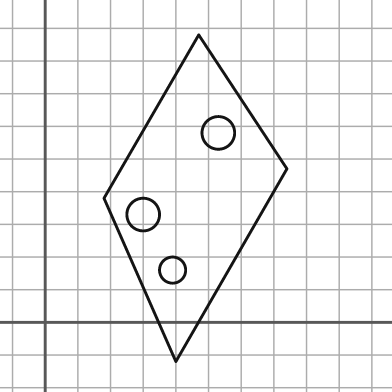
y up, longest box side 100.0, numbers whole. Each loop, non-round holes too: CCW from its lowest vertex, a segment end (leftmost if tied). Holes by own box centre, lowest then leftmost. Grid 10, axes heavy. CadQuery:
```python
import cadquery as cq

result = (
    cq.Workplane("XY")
    .moveTo(40.0, -12.0)
    .lineTo(74.0, 47.0)
    .lineTo(47.0, 88.0)
    .lineTo(18.0, 38.0)
    .close()
    .moveTo(39.0, 16.0)
    .circle(4.0)
    .moveTo(30.0, 33.0)
    .circle(5.0)
    .moveTo(53.0, 58.0)
    .circle(5.0)
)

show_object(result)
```